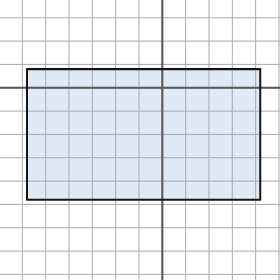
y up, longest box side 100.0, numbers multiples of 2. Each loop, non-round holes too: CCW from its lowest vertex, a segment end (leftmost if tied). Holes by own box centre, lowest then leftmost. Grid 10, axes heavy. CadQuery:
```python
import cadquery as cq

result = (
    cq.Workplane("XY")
    .moveTo(-58.0, -48.0)
    .lineTo(42.0, -48.0)
    .lineTo(42.0, 8.0)
    .lineTo(-58.0, 8.0)
    .close()
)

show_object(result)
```